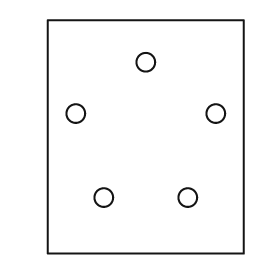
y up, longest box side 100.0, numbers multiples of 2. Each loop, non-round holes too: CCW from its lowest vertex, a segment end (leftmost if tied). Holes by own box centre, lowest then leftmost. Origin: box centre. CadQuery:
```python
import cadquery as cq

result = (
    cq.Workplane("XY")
    .moveTo(-42.0, -50.0)
    .lineTo(42.0, -50.0)
    .lineTo(42.0, 50.0)
    .lineTo(-42.0, 50.0)
    .close()
    .moveTo(-18.0, -26.0)
    .circle(4.0)
    .moveTo(18.0, -26.0)
    .circle(4.0)
    .moveTo(-30.0, 10.0)
    .circle(4.0)
    .moveTo(30.0, 10.0)
    .circle(4.0)
    .moveTo(0.0, 32.0)
    .circle(4.0)
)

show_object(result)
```